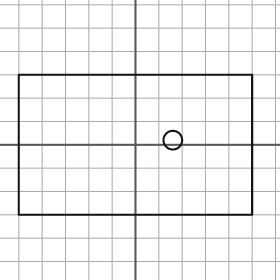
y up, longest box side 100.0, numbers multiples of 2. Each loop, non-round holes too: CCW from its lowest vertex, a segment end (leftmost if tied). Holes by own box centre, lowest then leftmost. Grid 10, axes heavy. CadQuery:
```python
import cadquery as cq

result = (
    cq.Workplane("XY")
    .moveTo(-50.0, -30.0)
    .lineTo(50.0, -30.0)
    .lineTo(50.0, 30.0)
    .lineTo(-50.0, 30.0)
    .close()
    .moveTo(16.0, 2.0)
    .circle(4.0)
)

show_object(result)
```